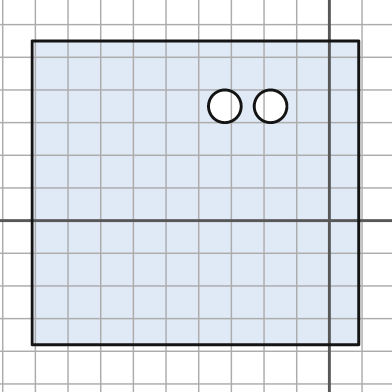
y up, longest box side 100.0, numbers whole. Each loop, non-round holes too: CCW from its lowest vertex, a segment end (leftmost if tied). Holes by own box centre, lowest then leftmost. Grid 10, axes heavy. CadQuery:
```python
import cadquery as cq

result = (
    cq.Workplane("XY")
    .moveTo(-91.0, -38.0)
    .lineTo(9.0, -38.0)
    .lineTo(9.0, 55.0)
    .lineTo(-91.0, 55.0)
    .close()
    .moveTo(-32.0, 35.0)
    .circle(5.0)
    .moveTo(-18.0, 35.0)
    .circle(5.0)
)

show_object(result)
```